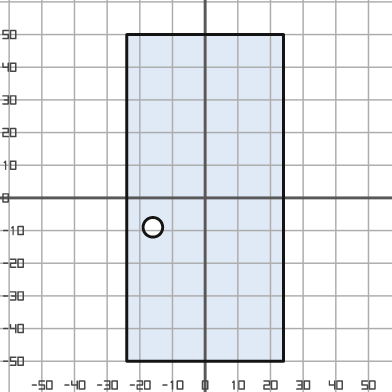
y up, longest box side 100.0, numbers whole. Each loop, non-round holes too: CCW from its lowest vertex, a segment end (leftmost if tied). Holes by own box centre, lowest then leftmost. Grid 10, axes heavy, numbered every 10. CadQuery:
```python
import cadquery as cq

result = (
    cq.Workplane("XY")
    .moveTo(-24.0, -50.0)
    .lineTo(24.0, -50.0)
    .lineTo(24.0, 50.0)
    .lineTo(-24.0, 50.0)
    .close()
    .moveTo(-16.0, -9.0)
    .circle(3.0)
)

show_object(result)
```